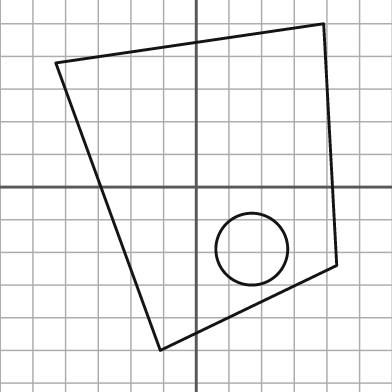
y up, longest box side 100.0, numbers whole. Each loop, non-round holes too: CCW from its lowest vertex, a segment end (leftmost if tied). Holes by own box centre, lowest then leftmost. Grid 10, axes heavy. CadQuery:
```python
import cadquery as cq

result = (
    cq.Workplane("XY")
    .moveTo(-11.0, -50.0)
    .lineTo(43.0, -24.0)
    .lineTo(39.0, 50.0)
    .lineTo(-43.0, 38.0)
    .close()
    .moveTo(17.0, -19.0)
    .circle(11.0)
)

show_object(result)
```